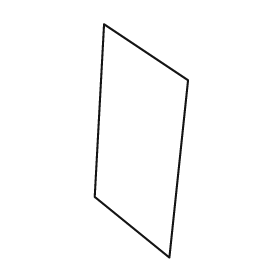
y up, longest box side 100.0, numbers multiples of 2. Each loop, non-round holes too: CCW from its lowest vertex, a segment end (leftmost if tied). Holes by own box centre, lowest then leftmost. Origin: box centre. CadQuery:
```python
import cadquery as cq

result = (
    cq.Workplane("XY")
    .moveTo(12.0, -50.0)
    .lineTo(20.0, 26.0)
    .lineTo(-16.0, 50.0)
    .lineTo(-20.0, -24.0)
    .close()
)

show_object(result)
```